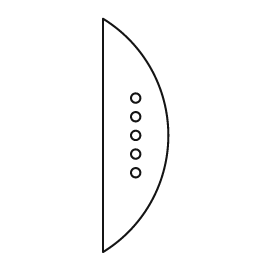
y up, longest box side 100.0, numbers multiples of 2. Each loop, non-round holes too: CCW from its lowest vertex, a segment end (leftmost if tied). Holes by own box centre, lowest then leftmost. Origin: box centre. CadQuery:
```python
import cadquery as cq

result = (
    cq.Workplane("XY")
    .moveTo(-14.0, -50.0)
    .threePointArc((14.0, 0.0), (-14.0, 50.0))
    .close()
    .moveTo(0.0, -16.0)
    .circle(2.0)
    .moveTo(0.0, -8.0)
    .circle(2.0)
    .moveTo(0.0, 0.0)
    .circle(2.0)
    .moveTo(0.0, 8.0)
    .circle(2.0)
    .moveTo(0.0, 16.0)
    .circle(2.0)
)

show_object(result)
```